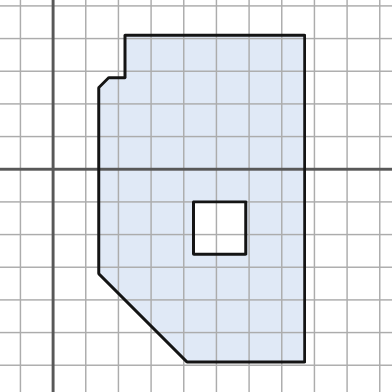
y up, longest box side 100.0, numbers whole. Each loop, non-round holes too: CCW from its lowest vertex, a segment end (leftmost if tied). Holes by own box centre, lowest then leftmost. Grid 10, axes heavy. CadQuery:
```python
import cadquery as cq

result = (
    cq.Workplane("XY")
    .moveTo(41.0, -59.0)
    .lineTo(77.0, -59.0)
    .lineTo(77.0, 41.0)
    .lineTo(22.0, 41.0)
    .lineTo(22.0, 28.0)
    .lineTo(17.0, 28.0)
    .lineTo(14.0, 25.0)
    .lineTo(14.0, -32.0)
    .close()
    .moveTo(43.0, -26.0)
    .lineTo(59.0, -26.0)
    .lineTo(59.0, -10.0)
    .lineTo(43.0, -10.0)
    .close()
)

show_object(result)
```